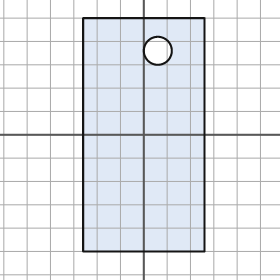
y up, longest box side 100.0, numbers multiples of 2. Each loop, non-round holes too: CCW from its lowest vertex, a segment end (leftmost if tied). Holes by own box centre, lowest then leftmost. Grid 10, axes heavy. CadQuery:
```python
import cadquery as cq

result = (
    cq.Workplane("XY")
    .moveTo(-26.0, -50.0)
    .lineTo(26.0, -50.0)
    .lineTo(26.0, 50.0)
    .lineTo(-26.0, 50.0)
    .close()
    .moveTo(6.0, 36.0)
    .circle(6.0)
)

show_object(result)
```